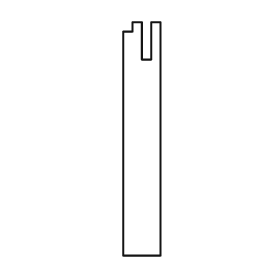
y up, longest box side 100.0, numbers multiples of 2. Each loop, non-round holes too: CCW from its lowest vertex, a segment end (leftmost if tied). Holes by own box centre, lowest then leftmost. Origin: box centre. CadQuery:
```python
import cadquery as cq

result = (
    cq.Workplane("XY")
    .moveTo(-8.0, -50.0)
    .lineTo(8.0, -50.0)
    .lineTo(8.0, 50.0)
    .lineTo(4.0, 50.0)
    .lineTo(4.0, 34.0)
    .lineTo(0.0, 34.0)
    .lineTo(0.0, 50.0)
    .lineTo(-4.0, 50.0)
    .lineTo(-4.0, 46.0)
    .lineTo(-8.0, 46.0)
    .close()
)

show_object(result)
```